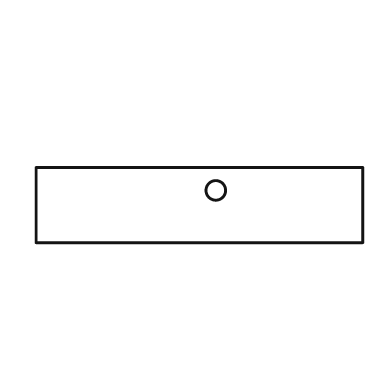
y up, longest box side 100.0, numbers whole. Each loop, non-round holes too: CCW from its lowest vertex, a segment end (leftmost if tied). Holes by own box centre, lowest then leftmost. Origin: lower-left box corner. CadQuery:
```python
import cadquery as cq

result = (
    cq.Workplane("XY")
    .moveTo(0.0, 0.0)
    .lineTo(100.0, 0.0)
    .lineTo(100.0, 23.0)
    .lineTo(0.0, 23.0)
    .close()
    .moveTo(55.0, 16.0)
    .circle(3.0)
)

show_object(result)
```